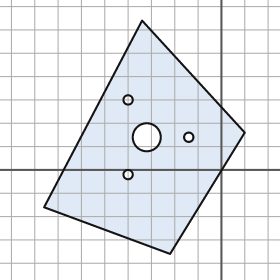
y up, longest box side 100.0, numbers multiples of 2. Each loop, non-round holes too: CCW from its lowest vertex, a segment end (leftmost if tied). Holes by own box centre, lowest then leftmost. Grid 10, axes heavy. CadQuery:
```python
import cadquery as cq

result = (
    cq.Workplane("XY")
    .moveTo(-22.0, -36.0)
    .lineTo(10.0, 16.0)
    .lineTo(-34.0, 64.0)
    .lineTo(-76.0, -16.0)
    .close()
    .moveTo(-40.0, -2.0)
    .circle(2.0)
    .moveTo(-32.0, 14.0)
    .circle(6.0)
    .moveTo(-14.0, 14.0)
    .circle(2.0)
    .moveTo(-40.0, 30.0)
    .circle(2.0)
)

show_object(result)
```